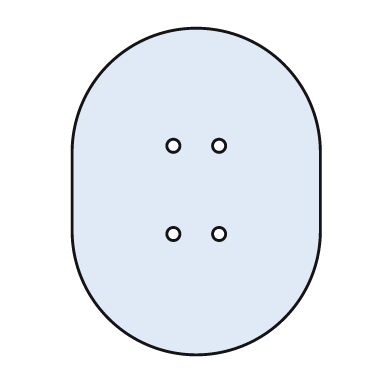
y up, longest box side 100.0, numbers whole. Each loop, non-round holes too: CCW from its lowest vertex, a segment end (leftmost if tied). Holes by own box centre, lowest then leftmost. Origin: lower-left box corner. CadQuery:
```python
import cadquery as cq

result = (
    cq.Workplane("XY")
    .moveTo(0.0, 38.0)
    .threePointArc((38.0, 0.0), (76.0, 38.0))
    .lineTo(76.0, 62.0)
    .threePointArc((38.0, 100.0), (0.0, 62.0))
    .close()
    .moveTo(31.0, 37.0)
    .circle(2.0)
    .moveTo(45.0, 37.0)
    .circle(2.0)
    .moveTo(31.0, 64.0)
    .circle(2.0)
    .moveTo(45.0, 64.0)
    .circle(2.0)
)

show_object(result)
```